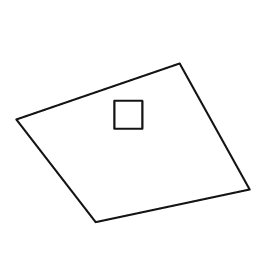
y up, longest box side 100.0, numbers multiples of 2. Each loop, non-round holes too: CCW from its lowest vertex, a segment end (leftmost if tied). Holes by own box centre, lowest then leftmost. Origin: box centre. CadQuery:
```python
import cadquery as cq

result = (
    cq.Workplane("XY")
    .moveTo(-16.0, -34.0)
    .lineTo(50.0, -20.0)
    .lineTo(20.0, 34.0)
    .lineTo(-50.0, 10.0)
    .close()
    .moveTo(-8.0, 6.0)
    .lineTo(4.0, 6.0)
    .lineTo(4.0, 18.0)
    .lineTo(-8.0, 18.0)
    .close()
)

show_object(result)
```